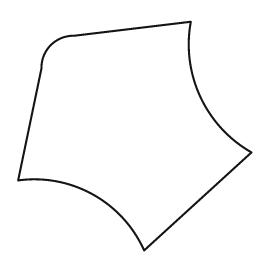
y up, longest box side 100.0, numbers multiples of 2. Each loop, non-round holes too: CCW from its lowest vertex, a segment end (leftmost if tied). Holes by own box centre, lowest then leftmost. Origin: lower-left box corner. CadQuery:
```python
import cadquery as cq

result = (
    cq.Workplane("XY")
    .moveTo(54.0, 0.0)
    .lineTo(100.0, 42.0)
    .threePointArc((78.0, 66.0), (74.0, 98.0))
    .lineTo(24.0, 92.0)
    .threePointArc((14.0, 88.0), (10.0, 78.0))
    .lineTo(0.0, 30.0)
    .threePointArc((32.0, 24.0), (54.0, 0.0))
    .close()
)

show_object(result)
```